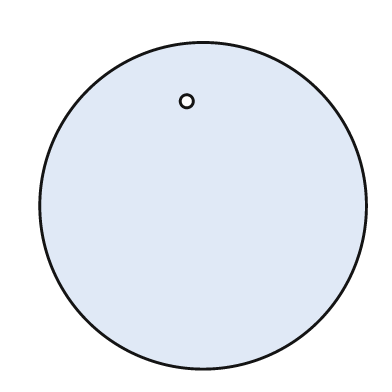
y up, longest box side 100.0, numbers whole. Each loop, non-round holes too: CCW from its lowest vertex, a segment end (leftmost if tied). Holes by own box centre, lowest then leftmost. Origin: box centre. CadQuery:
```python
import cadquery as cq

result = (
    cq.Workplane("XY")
    .moveTo(0.0, 0.0)
    .circle(50.0)
    .moveTo(-5.0, 32.0)
    .circle(2.0)
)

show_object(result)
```